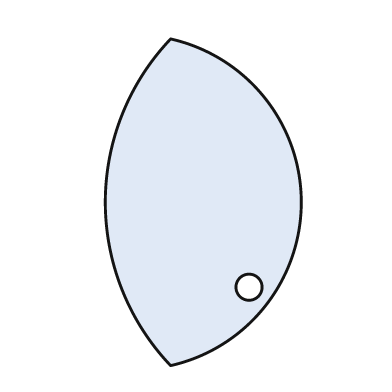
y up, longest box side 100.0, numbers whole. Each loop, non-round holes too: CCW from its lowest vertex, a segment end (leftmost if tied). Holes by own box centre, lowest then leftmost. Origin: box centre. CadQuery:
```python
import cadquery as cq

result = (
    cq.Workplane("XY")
    .moveTo(-10.0, -50.0)
    .threePointArc((30.0, 0.0), (-10.0, 50.0))
    .threePointArc((-30.0, 0.0), (-10.0, -50.0))
    .close()
    .moveTo(14.0, -26.0)
    .circle(4.0)
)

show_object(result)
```